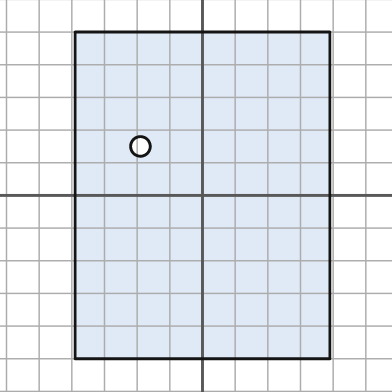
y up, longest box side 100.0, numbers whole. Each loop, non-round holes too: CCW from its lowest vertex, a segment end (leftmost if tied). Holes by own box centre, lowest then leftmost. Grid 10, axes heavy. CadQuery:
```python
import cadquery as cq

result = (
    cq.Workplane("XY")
    .moveTo(-39.0, -50.0)
    .lineTo(39.0, -50.0)
    .lineTo(39.0, 50.0)
    .lineTo(-39.0, 50.0)
    .close()
    .moveTo(-19.0, 15.0)
    .circle(3.0)
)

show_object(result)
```